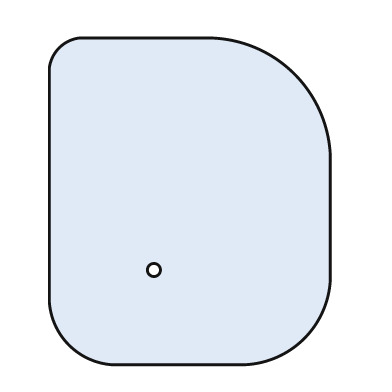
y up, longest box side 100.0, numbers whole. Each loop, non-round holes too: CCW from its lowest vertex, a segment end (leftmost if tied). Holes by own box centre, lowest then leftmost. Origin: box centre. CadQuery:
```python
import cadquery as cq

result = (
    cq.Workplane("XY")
    .moveTo(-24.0, -50.0)
    .lineTo(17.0, -50.0)
    .threePointArc((35.0, -42.0), (43.0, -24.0))
    .lineTo(43.0, 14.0)
    .threePointArc((32.0, 39.0), (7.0, 50.0))
    .lineTo(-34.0, 50.0)
    .threePointArc((-40.0, 47.0), (-43.0, 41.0))
    .lineTo(-43.0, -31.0)
    .threePointArc((-37.0, -44.0), (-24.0, -50.0))
    .close()
    .moveTo(-11.0, -21.0)
    .circle(2.0)
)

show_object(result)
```